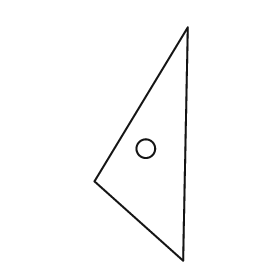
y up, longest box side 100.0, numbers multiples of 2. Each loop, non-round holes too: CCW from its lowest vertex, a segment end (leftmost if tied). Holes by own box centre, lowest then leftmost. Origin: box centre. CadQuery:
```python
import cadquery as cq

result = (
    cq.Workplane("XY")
    .moveTo(18.0, -50.0)
    .lineTo(20.0, 50.0)
    .lineTo(-20.0, -16.0)
    .close()
    .moveTo(2.0, -2.0)
    .circle(4.0)
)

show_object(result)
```